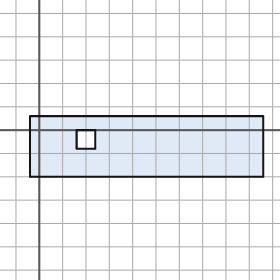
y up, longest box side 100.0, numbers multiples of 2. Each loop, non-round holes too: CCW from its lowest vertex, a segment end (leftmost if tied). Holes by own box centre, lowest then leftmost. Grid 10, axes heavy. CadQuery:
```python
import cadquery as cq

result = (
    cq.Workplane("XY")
    .moveTo(-4.0, -20.0)
    .lineTo(96.0, -20.0)
    .lineTo(96.0, 6.0)
    .lineTo(-4.0, 6.0)
    .close()
    .moveTo(16.0, -8.0)
    .lineTo(24.0, -8.0)
    .lineTo(24.0, 0.0)
    .lineTo(16.0, 0.0)
    .close()
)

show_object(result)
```